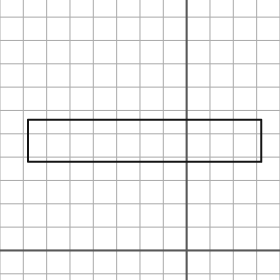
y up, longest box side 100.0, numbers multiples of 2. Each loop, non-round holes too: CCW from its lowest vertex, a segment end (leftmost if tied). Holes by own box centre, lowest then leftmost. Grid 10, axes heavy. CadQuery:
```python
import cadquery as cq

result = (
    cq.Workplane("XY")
    .moveTo(-68.0, 38.0)
    .lineTo(32.0, 38.0)
    .lineTo(32.0, 56.0)
    .lineTo(-68.0, 56.0)
    .close()
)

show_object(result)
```